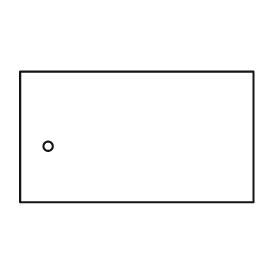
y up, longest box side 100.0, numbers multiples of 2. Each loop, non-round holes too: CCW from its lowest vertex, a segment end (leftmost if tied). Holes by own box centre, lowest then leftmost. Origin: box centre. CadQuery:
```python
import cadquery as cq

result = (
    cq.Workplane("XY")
    .moveTo(-50.0, -28.0)
    .lineTo(50.0, -28.0)
    .lineTo(50.0, 28.0)
    .lineTo(-50.0, 28.0)
    .close()
    .moveTo(-38.0, -4.0)
    .circle(2.0)
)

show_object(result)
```